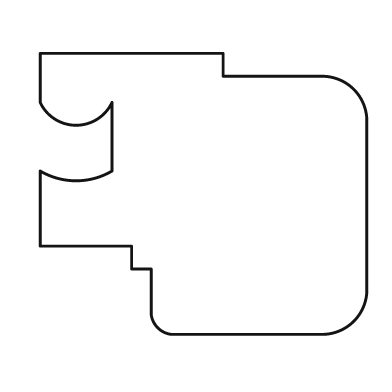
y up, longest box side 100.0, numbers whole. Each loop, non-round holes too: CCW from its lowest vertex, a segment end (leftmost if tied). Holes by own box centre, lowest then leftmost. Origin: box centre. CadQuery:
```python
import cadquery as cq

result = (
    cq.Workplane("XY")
    .moveTo(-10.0, -43.0)
    .lineTo(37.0, -43.0)
    .threePointArc((46.0, -39.0), (50.0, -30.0))
    .lineTo(50.0, 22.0)
    .threePointArc((46.0, 32.0), (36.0, 36.0))
    .lineTo(6.0, 36.0)
    .lineTo(6.0, 43.0)
    .lineTo(-50.0, 43.0)
    .lineTo(-50.0, 28.0)
    .threePointArc((-39.0, 21.0), (-28.0, 28.0))
    .lineTo(-28.0, 7.0)
    .threePointArc((-39.0, 4.0), (-50.0, 7.0))
    .lineTo(-50.0, -16.0)
    .lineTo(-22.0, -16.0)
    .lineTo(-22.0, -23.0)
    .lineTo(-16.0, -23.0)
    .lineTo(-16.0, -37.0)
    .threePointArc((-14.0, -41.0), (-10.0, -43.0))
    .close()
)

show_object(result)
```